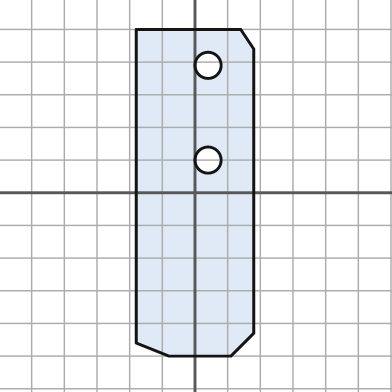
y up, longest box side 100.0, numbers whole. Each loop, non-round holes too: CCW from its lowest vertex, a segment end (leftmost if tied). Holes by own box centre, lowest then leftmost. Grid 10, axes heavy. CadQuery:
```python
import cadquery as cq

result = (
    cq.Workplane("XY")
    .moveTo(-8.0, -50.0)
    .lineTo(11.0, -50.0)
    .lineTo(18.0, -43.0)
    .lineTo(18.0, 44.0)
    .lineTo(14.0, 50.0)
    .lineTo(-18.0, 50.0)
    .lineTo(-18.0, -46.0)
    .close()
    .moveTo(4.0, 10.0)
    .circle(4.0)
    .moveTo(4.0, 39.0)
    .circle(4.0)
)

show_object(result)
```